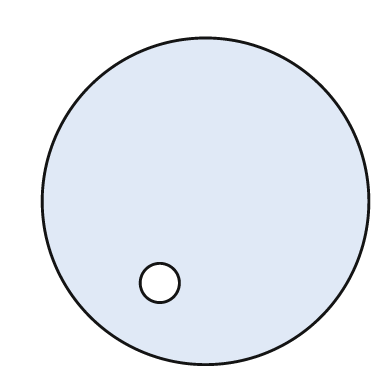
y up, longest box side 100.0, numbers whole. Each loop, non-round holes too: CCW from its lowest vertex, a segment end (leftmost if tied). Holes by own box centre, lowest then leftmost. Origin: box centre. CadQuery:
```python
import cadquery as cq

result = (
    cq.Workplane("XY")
    .moveTo(0.0, 0.0)
    .circle(50.0)
    .moveTo(-14.0, -25.0)
    .circle(6.0)
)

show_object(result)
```